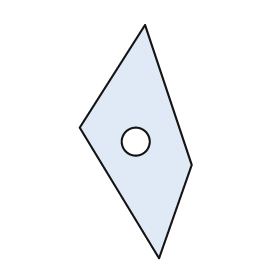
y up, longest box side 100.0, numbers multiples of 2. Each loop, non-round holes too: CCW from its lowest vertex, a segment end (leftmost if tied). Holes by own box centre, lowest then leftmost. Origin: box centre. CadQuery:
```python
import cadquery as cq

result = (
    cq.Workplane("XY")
    .moveTo(10.0, -50.0)
    .lineTo(24.0, -10.0)
    .lineTo(4.0, 50.0)
    .lineTo(-24.0, 6.0)
    .close()
    .moveTo(0.0, 0.0)
    .circle(6.0)
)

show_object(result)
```